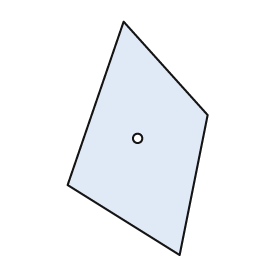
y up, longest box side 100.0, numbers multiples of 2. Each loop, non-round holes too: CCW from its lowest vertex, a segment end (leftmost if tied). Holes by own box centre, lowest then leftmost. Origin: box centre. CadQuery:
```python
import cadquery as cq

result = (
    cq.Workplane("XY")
    .moveTo(18.0, -50.0)
    .lineTo(30.0, 10.0)
    .lineTo(-6.0, 50.0)
    .lineTo(-30.0, -20.0)
    .close()
    .moveTo(0.0, 0.0)
    .circle(2.0)
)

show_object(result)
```